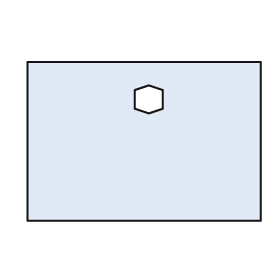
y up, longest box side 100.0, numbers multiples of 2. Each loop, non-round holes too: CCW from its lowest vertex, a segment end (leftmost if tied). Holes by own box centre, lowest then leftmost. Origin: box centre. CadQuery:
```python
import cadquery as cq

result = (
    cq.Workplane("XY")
    .moveTo(-50.0, -34.0)
    .lineTo(50.0, -34.0)
    .lineTo(50.0, 34.0)
    .lineTo(-50.0, 34.0)
    .close()
    .moveTo(2.0, 12.0)
    .lineTo(8.0, 14.0)
    .lineTo(8.0, 22.0)
    .lineTo(2.0, 24.0)
    .lineTo(-4.0, 22.0)
    .lineTo(-4.0, 14.0)
    .close()
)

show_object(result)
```